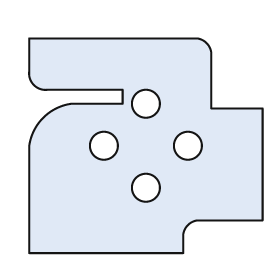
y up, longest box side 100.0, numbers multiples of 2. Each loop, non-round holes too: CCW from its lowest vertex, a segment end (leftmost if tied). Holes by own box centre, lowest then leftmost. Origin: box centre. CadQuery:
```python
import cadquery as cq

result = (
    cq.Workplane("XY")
    .moveTo(-50.0, -46.0)
    .lineTo(16.0, -46.0)
    .lineTo(16.0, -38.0)
    .threePointArc((18.0, -34.0), (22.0, -32.0))
    .lineTo(50.0, -32.0)
    .lineTo(50.0, 16.0)
    .lineTo(28.0, 16.0)
    .lineTo(28.0, 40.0)
    .threePointArc((26.0, 44.0), (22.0, 46.0))
    .lineTo(-50.0, 46.0)
    .lineTo(-50.0, 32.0)
    .threePointArc((-48.0, 26.0), (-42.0, 24.0))
    .lineTo(-10.0, 24.0)
    .lineTo(-10.0, 18.0)
    .lineTo(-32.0, 18.0)
    .threePointArc((-44.0, 12.0), (-50.0, 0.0))
    .close()
    .moveTo(0.0, -18.0)
    .circle(6.0)
    .moveTo(-18.0, 0.0)
    .circle(6.0)
    .moveTo(18.0, 0.0)
    .circle(6.0)
    .moveTo(0.0, 18.0)
    .circle(6.0)
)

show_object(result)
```